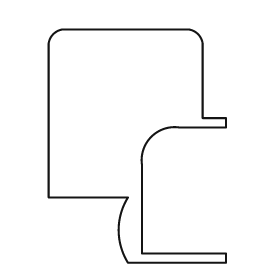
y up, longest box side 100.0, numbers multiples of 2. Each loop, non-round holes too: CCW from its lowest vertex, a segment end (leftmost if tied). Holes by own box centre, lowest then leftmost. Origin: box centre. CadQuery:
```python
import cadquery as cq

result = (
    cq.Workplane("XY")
    .moveTo(-4.0, -50.0)
    .lineTo(38.0, -50.0)
    .lineTo(38.0, -46.0)
    .lineTo(2.0, -46.0)
    .lineTo(2.0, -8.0)
    .threePointArc((6.0, 4.0), (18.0, 8.0))
    .lineTo(38.0, 8.0)
    .lineTo(38.0, 12.0)
    .lineTo(28.0, 12.0)
    .lineTo(28.0, 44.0)
    .threePointArc((26.0, 48.0), (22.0, 50.0))
    .lineTo(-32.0, 50.0)
    .threePointArc((-36.0, 48.0), (-38.0, 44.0))
    .lineTo(-38.0, -22.0)
    .lineTo(-4.0, -22.0)
    .threePointArc((-8.0, -36.0), (-4.0, -50.0))
    .close()
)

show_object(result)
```